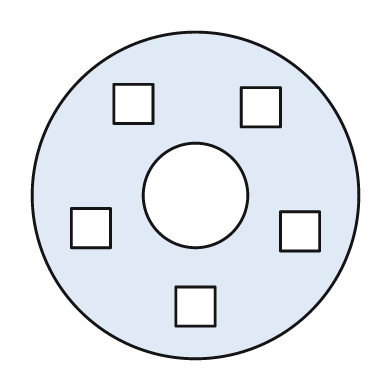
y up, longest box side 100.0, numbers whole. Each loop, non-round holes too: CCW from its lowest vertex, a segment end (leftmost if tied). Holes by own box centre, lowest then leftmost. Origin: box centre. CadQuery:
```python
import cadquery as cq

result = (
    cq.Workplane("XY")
    .moveTo(0.0, 0.0)
    .circle(50.0)
    .moveTo(-6.0, -40.0)
    .lineTo(6.0, -40.0)
    .lineTo(6.0, -28.0)
    .lineTo(-6.0, -28.0)
    .close()
    .moveTo(26.0, -17.0)
    .lineTo(38.0, -17.0)
    .lineTo(38.0, -5.0)
    .lineTo(26.0, -5.0)
    .close()
    .moveTo(-38.0, -16.0)
    .lineTo(-26.0, -16.0)
    .lineTo(-26.0, -4.0)
    .lineTo(-38.0, -4.0)
    .close()
    .moveTo(0.0, 0.0)
    .circle(16.0)
    .moveTo(14.0, 21.0)
    .lineTo(26.0, 21.0)
    .lineTo(26.0, 33.0)
    .lineTo(14.0, 33.0)
    .close()
    .moveTo(-25.0, 22.0)
    .lineTo(-13.0, 22.0)
    .lineTo(-13.0, 34.0)
    .lineTo(-25.0, 34.0)
    .close()
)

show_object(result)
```